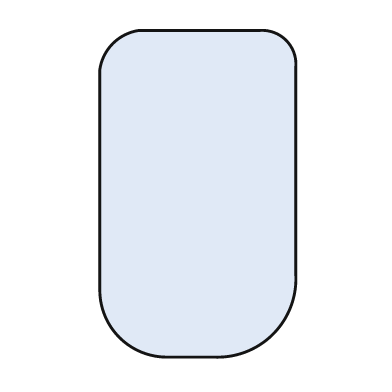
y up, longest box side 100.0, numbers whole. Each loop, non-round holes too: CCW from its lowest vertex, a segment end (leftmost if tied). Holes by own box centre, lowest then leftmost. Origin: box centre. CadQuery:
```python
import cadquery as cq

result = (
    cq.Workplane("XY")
    .moveTo(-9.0, -50.0)
    .lineTo(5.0, -50.0)
    .threePointArc((23.0, -43.0), (30.0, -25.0))
    .lineTo(30.0, 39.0)
    .threePointArc((27.0, 47.0), (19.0, 50.0))
    .lineTo(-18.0, 50.0)
    .threePointArc((-26.0, 46.0), (-30.0, 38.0))
    .lineTo(-30.0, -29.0)
    .threePointArc((-24.0, -44.0), (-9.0, -50.0))
    .close()
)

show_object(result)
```